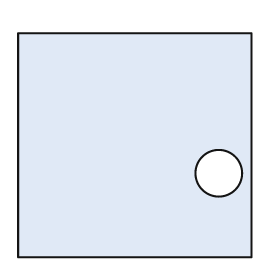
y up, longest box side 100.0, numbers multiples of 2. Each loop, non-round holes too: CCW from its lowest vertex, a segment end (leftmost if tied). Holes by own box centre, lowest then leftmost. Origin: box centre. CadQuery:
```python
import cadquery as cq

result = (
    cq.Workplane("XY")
    .moveTo(-50.0, -48.0)
    .lineTo(50.0, -48.0)
    .lineTo(50.0, 48.0)
    .lineTo(-50.0, 48.0)
    .close()
    .moveTo(36.0, -12.0)
    .circle(10.0)
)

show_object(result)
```